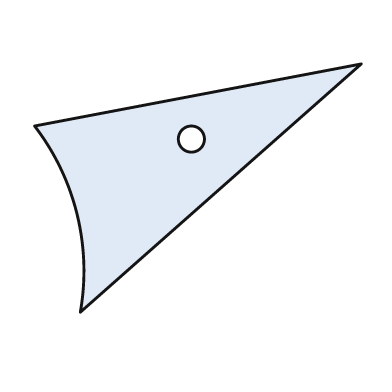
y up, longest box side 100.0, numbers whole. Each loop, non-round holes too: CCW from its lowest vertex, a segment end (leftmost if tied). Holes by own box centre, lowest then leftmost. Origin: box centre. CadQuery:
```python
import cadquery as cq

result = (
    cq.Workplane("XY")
    .moveTo(-36.0, -38.0)
    .lineTo(50.0, 38.0)
    .lineTo(-50.0, 19.0)
    .threePointArc((-37.0, -8.0), (-36.0, -38.0))
    .close()
    .moveTo(-2.0, 15.0)
    .circle(4.0)
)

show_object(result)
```